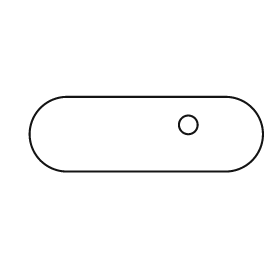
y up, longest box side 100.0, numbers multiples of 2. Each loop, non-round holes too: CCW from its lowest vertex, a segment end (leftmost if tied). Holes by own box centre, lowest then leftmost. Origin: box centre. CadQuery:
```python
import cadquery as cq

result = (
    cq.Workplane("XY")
    .moveTo(-34.0, -16.0)
    .lineTo(34.0, -16.0)
    .threePointArc((50.0, 0.0), (34.0, 16.0))
    .lineTo(-34.0, 16.0)
    .threePointArc((-50.0, 0.0), (-34.0, -16.0))
    .close()
    .moveTo(18.0, 4.0)
    .circle(4.0)
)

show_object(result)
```